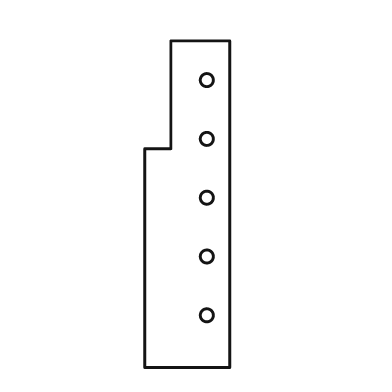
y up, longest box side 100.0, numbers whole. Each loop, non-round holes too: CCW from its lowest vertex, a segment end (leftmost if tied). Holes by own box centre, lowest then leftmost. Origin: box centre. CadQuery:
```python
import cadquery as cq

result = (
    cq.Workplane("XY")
    .moveTo(-13.0, -50.0)
    .lineTo(13.0, -50.0)
    .lineTo(13.0, 50.0)
    .lineTo(-5.0, 50.0)
    .lineTo(-5.0, 17.0)
    .lineTo(-13.0, 17.0)
    .close()
    .moveTo(6.0, -34.0)
    .circle(2.0)
    .moveTo(6.0, -16.0)
    .circle(2.0)
    .moveTo(6.0, 2.0)
    .circle(2.0)
    .moveTo(6.0, 20.0)
    .circle(2.0)
    .moveTo(6.0, 38.0)
    .circle(2.0)
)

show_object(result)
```